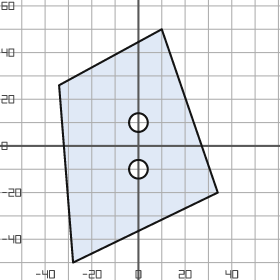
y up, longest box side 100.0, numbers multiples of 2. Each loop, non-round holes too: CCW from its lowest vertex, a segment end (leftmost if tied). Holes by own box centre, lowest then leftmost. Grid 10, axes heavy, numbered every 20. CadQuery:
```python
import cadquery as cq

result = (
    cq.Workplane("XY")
    .moveTo(-28.0, -50.0)
    .lineTo(34.0, -20.0)
    .lineTo(10.0, 50.0)
    .lineTo(-34.0, 26.0)
    .close()
    .moveTo(0.0, -10.0)
    .circle(4.0)
    .moveTo(0.0, 10.0)
    .circle(4.0)
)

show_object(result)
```